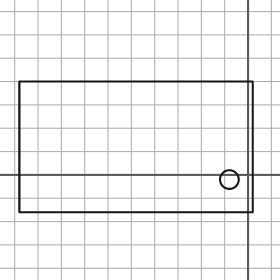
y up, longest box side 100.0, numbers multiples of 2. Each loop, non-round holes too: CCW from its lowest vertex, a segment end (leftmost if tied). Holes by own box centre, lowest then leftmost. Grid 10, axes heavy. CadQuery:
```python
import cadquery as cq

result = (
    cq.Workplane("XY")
    .moveTo(-98.0, -16.0)
    .lineTo(2.0, -16.0)
    .lineTo(2.0, 40.0)
    .lineTo(-98.0, 40.0)
    .close()
    .moveTo(-8.0, -2.0)
    .circle(4.0)
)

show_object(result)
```